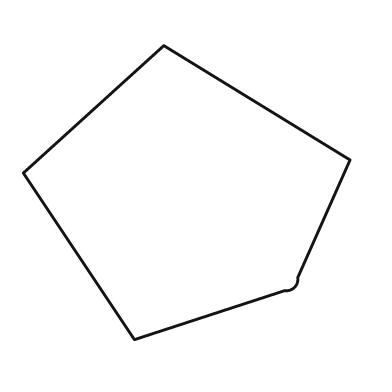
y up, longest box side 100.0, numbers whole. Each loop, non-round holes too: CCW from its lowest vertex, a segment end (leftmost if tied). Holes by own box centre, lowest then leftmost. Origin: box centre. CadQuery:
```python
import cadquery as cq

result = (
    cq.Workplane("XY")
    .moveTo(-16.0, -45.0)
    .lineTo(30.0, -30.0)
    .threePointArc((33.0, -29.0), (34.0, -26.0))
    .lineTo(50.0, 10.0)
    .lineTo(-7.0, 45.0)
    .lineTo(-50.0, 6.0)
    .close()
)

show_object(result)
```